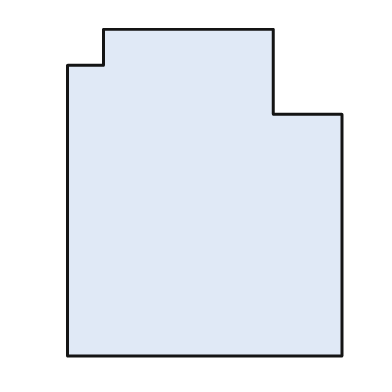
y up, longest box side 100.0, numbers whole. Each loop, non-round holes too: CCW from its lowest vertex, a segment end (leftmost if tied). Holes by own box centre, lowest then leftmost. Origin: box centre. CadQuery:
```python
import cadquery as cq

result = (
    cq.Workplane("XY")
    .moveTo(-42.0, -50.0)
    .lineTo(42.0, -50.0)
    .lineTo(42.0, 24.0)
    .lineTo(21.0, 24.0)
    .lineTo(21.0, 50.0)
    .lineTo(-31.0, 50.0)
    .lineTo(-31.0, 39.0)
    .lineTo(-42.0, 39.0)
    .close()
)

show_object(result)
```